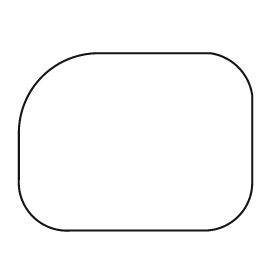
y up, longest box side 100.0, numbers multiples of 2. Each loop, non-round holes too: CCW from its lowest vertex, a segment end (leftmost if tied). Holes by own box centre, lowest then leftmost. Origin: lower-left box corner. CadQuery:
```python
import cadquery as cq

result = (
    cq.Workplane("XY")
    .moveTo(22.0, 0.0)
    .lineTo(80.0, 0.0)
    .threePointArc((94.0, 6.0), (100.0, 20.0))
    .lineTo(100.0, 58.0)
    .threePointArc((94.0, 70.0), (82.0, 76.0))
    .lineTo(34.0, 76.0)
    .threePointArc((10.0, 66.0), (0.0, 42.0))
    .lineTo(0.0, 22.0)
    .threePointArc((6.0, 6.0), (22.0, 0.0))
    .close()
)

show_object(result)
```